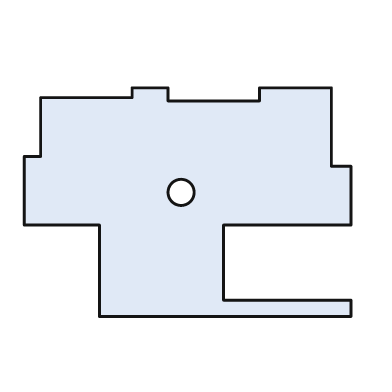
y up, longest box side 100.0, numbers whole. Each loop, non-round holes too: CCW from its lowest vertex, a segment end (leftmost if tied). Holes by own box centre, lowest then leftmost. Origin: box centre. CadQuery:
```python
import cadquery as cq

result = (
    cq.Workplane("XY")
    .moveTo(-27.0, -35.0)
    .lineTo(50.0, -35.0)
    .lineTo(50.0, -30.0)
    .lineTo(11.0, -30.0)
    .lineTo(11.0, -7.0)
    .lineTo(50.0, -7.0)
    .lineTo(50.0, 11.0)
    .lineTo(44.0, 11.0)
    .lineTo(44.0, 35.0)
    .lineTo(22.0, 35.0)
    .lineTo(22.0, 31.0)
    .lineTo(-6.0, 31.0)
    .lineTo(-6.0, 35.0)
    .lineTo(-17.0, 35.0)
    .lineTo(-17.0, 32.0)
    .lineTo(-45.0, 32.0)
    .lineTo(-45.0, 14.0)
    .lineTo(-50.0, 14.0)
    .lineTo(-50.0, -7.0)
    .lineTo(-27.0, -7.0)
    .close()
    .moveTo(-2.0, 3.0)
    .circle(4.0)
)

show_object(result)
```